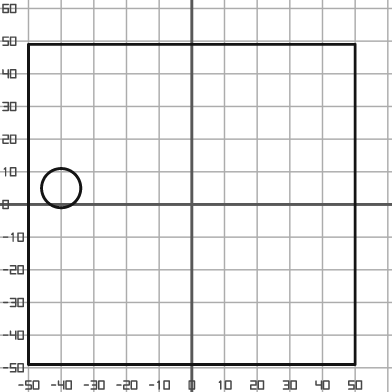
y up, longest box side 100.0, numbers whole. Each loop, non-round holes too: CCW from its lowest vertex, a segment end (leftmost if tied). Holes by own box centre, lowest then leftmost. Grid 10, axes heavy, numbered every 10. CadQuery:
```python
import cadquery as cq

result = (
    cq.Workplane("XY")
    .moveTo(-50.0, -49.0)
    .lineTo(50.0, -49.0)
    .lineTo(50.0, 49.0)
    .lineTo(-50.0, 49.0)
    .close()
    .moveTo(-40.0, 5.0)
    .circle(6.0)
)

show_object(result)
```